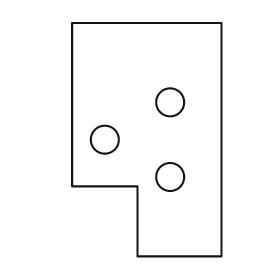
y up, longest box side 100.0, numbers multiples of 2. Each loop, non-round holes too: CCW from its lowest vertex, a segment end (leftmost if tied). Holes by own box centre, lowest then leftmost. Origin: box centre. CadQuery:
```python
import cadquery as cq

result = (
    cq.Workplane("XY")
    .moveTo(-4.0, -50.0)
    .lineTo(32.0, -50.0)
    .lineTo(32.0, 50.0)
    .lineTo(-32.0, 50.0)
    .lineTo(-32.0, -20.0)
    .lineTo(-4.0, -20.0)
    .close()
    .moveTo(10.0, -16.0)
    .circle(6.0)
    .moveTo(-18.0, 0.0)
    .circle(6.0)
    .moveTo(10.0, 16.0)
    .circle(6.0)
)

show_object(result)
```